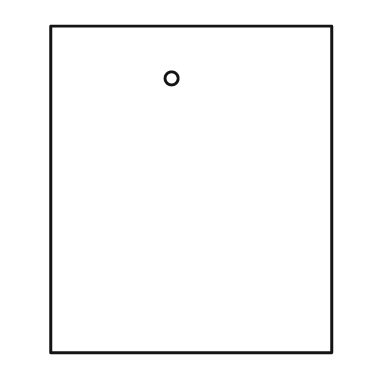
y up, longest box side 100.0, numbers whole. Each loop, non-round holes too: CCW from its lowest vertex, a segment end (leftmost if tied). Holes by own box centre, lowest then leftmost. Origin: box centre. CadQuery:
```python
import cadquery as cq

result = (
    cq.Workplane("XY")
    .moveTo(-43.0, -50.0)
    .lineTo(43.0, -50.0)
    .lineTo(43.0, 50.0)
    .lineTo(-43.0, 50.0)
    .close()
    .moveTo(-6.0, 34.0)
    .circle(2.0)
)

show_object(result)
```